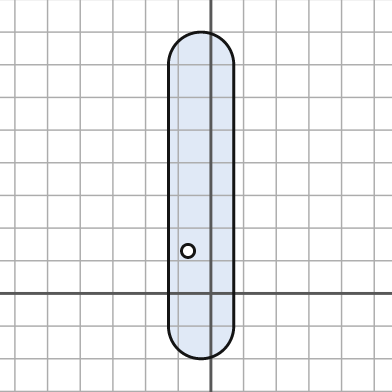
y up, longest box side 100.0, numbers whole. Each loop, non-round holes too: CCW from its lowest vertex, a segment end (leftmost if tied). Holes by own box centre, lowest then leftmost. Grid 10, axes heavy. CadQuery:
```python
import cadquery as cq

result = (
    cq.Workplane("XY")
    .moveTo(-13.0, -10.0)
    .threePointArc((-3.0, -20.0), (7.0, -10.0))
    .lineTo(7.0, 70.0)
    .threePointArc((-3.0, 80.0), (-13.0, 70.0))
    .close()
    .moveTo(-7.0, 13.0)
    .circle(2.0)
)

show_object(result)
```